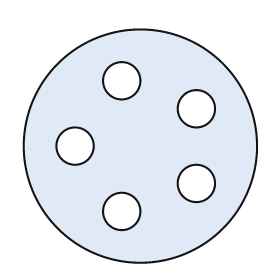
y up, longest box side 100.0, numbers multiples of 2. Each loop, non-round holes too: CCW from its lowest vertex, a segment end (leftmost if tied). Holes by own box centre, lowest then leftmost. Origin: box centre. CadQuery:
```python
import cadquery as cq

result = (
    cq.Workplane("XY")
    .moveTo(0.0, 0.0)
    .circle(50.0)
    .moveTo(-8.0, -28.0)
    .circle(8.0)
    .moveTo(24.0, -16.0)
    .circle(8.0)
    .moveTo(-28.0, 0.0)
    .circle(8.0)
    .moveTo(24.0, 16.0)
    .circle(8.0)
    .moveTo(-8.0, 28.0)
    .circle(8.0)
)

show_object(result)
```